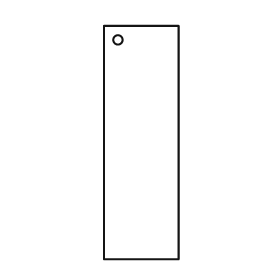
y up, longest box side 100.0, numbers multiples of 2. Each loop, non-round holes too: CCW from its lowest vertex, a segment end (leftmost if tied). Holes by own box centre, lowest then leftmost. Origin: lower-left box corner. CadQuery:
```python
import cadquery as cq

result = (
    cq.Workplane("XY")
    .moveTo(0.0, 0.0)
    .lineTo(32.0, 0.0)
    .lineTo(32.0, 100.0)
    .lineTo(0.0, 100.0)
    .close()
    .moveTo(6.0, 94.0)
    .circle(2.0)
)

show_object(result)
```